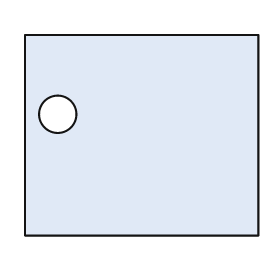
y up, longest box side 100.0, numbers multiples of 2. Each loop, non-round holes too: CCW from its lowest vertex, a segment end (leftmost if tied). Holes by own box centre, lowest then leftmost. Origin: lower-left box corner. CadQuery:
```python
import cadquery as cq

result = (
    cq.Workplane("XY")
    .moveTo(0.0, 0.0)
    .lineTo(100.0, 0.0)
    .lineTo(100.0, 86.0)
    .lineTo(0.0, 86.0)
    .close()
    .moveTo(14.0, 52.0)
    .circle(8.0)
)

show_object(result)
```